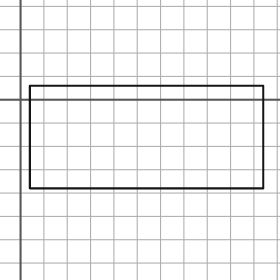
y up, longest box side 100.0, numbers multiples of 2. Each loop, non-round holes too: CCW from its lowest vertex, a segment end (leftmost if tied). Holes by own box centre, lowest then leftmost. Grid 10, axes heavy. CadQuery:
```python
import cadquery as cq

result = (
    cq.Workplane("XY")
    .moveTo(4.0, -38.0)
    .lineTo(104.0, -38.0)
    .lineTo(104.0, 6.0)
    .lineTo(4.0, 6.0)
    .close()
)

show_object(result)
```